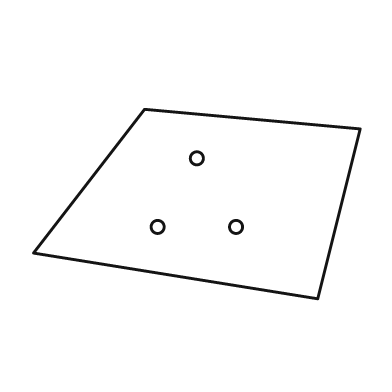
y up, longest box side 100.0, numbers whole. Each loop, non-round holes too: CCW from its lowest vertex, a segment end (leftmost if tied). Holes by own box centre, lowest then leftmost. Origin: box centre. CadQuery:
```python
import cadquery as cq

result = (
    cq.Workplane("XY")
    .moveTo(37.0, -29.0)
    .lineTo(50.0, 23.0)
    .lineTo(-16.0, 29.0)
    .lineTo(-50.0, -15.0)
    .close()
    .moveTo(-12.0, -7.0)
    .circle(2.0)
    .moveTo(12.0, -7.0)
    .circle(2.0)
    .moveTo(0.0, 14.0)
    .circle(2.0)
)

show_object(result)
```